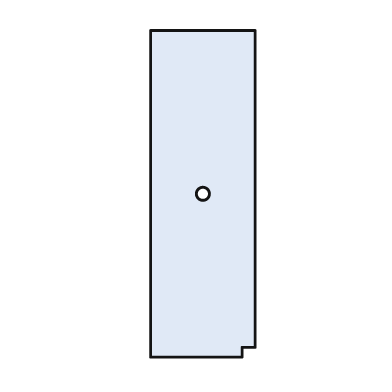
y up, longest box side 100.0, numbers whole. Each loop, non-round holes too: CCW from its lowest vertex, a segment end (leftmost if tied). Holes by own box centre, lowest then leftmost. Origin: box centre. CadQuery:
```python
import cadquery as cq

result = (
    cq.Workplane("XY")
    .moveTo(-16.0, -50.0)
    .lineTo(12.0, -50.0)
    .lineTo(12.0, -47.0)
    .lineTo(16.0, -47.0)
    .lineTo(16.0, 50.0)
    .lineTo(-16.0, 50.0)
    .close()
    .moveTo(0.0, 0.0)
    .circle(2.0)
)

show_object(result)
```